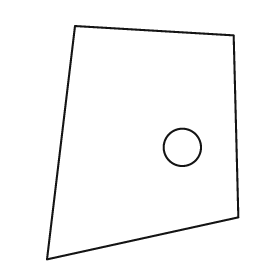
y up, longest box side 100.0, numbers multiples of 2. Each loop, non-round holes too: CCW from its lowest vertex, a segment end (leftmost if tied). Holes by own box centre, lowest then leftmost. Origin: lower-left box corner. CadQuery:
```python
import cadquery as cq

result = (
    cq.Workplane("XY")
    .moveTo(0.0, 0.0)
    .lineTo(82.0, 18.0)
    .lineTo(80.0, 96.0)
    .lineTo(12.0, 100.0)
    .close()
    .moveTo(58.0, 48.0)
    .circle(8.0)
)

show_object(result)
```